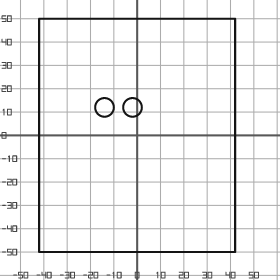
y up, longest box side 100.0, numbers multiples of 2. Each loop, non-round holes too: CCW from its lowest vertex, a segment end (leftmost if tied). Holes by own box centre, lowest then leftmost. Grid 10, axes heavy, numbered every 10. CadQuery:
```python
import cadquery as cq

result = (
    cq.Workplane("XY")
    .moveTo(-42.0, -50.0)
    .lineTo(42.0, -50.0)
    .lineTo(42.0, 50.0)
    .lineTo(-42.0, 50.0)
    .close()
    .moveTo(-14.0, 12.0)
    .circle(4.0)
    .moveTo(-2.0, 12.0)
    .circle(4.0)
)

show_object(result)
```